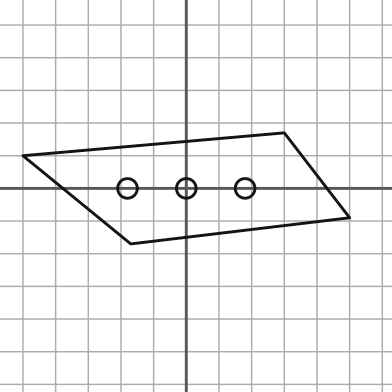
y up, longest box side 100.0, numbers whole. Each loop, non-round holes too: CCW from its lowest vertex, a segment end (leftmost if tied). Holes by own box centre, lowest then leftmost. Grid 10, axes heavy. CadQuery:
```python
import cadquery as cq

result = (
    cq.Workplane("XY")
    .moveTo(-17.0, -17.0)
    .lineTo(50.0, -9.0)
    .lineTo(30.0, 17.0)
    .lineTo(-50.0, 10.0)
    .close()
    .moveTo(-18.0, 0.0)
    .circle(3.0)
    .moveTo(0.0, 0.0)
    .circle(3.0)
    .moveTo(18.0, 0.0)
    .circle(3.0)
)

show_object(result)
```